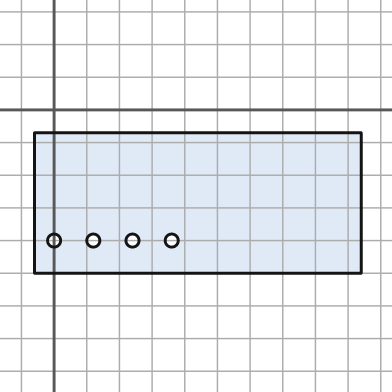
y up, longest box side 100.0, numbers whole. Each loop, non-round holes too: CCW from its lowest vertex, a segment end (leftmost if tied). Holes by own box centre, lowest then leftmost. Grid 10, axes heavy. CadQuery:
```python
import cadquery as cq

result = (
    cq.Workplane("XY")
    .moveTo(-6.0, -50.0)
    .lineTo(94.0, -50.0)
    .lineTo(94.0, -7.0)
    .lineTo(-6.0, -7.0)
    .close()
    .moveTo(0.0, -40.0)
    .circle(2.0)
    .moveTo(12.0, -40.0)
    .circle(2.0)
    .moveTo(24.0, -40.0)
    .circle(2.0)
    .moveTo(36.0, -40.0)
    .circle(2.0)
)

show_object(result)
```